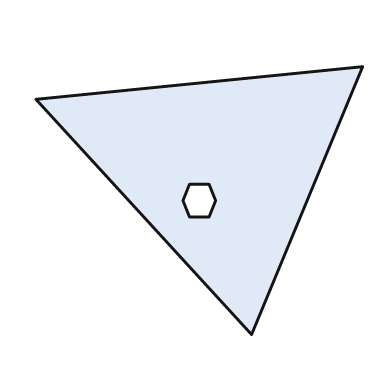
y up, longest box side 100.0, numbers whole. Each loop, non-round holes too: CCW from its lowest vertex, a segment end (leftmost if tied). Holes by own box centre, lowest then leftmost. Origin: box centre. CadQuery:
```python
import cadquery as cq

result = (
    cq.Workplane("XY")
    .moveTo(16.0, -41.0)
    .lineTo(50.0, 41.0)
    .lineTo(-50.0, 31.0)
    .close()
    .moveTo(-3.0, -5.0)
    .lineTo(3.0, -5.0)
    .lineTo(5.0, 0.0)
    .lineTo(3.0, 5.0)
    .lineTo(-3.0, 5.0)
    .lineTo(-5.0, 0.0)
    .close()
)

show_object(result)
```